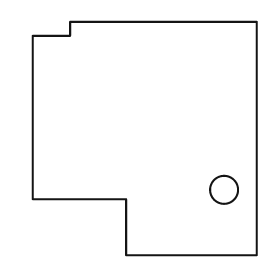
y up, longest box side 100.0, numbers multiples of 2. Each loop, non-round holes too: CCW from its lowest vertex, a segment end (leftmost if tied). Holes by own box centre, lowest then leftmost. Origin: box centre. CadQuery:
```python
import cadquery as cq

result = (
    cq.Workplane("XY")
    .moveTo(-8.0, -50.0)
    .lineTo(48.0, -50.0)
    .lineTo(48.0, 50.0)
    .lineTo(-32.0, 50.0)
    .lineTo(-32.0, 44.0)
    .lineTo(-48.0, 44.0)
    .lineTo(-48.0, -26.0)
    .lineTo(-8.0, -26.0)
    .close()
    .moveTo(34.0, -22.0)
    .circle(6.0)
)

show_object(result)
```